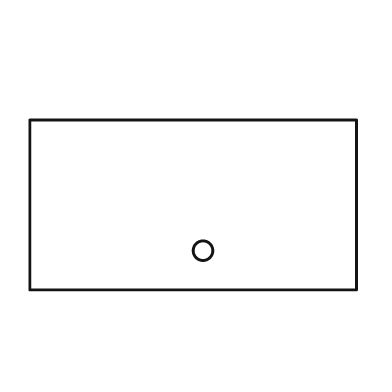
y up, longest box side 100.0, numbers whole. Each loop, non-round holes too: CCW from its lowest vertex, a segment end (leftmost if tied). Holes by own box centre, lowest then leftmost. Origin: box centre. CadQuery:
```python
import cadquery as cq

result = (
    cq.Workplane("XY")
    .moveTo(-50.0, -26.0)
    .lineTo(50.0, -26.0)
    .lineTo(50.0, 26.0)
    .lineTo(-50.0, 26.0)
    .close()
    .moveTo(3.0, -14.0)
    .circle(3.0)
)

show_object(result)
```